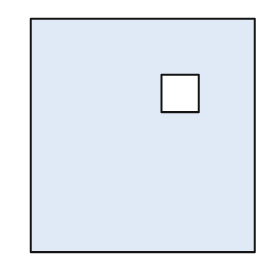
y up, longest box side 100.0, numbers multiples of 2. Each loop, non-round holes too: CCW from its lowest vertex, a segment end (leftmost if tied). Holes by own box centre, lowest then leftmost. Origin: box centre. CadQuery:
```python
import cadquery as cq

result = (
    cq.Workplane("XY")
    .moveTo(-48.0, -50.0)
    .lineTo(48.0, -50.0)
    .lineTo(48.0, 50.0)
    .lineTo(-48.0, 50.0)
    .close()
    .moveTo(8.0, 10.0)
    .lineTo(24.0, 10.0)
    .lineTo(24.0, 26.0)
    .lineTo(8.0, 26.0)
    .close()
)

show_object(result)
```